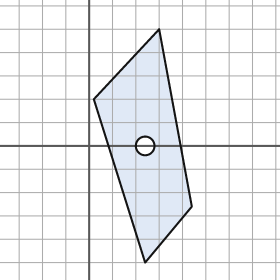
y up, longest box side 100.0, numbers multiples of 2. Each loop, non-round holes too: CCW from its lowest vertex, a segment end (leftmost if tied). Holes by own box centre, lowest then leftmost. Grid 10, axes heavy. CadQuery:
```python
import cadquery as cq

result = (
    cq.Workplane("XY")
    .moveTo(24.0, -50.0)
    .lineTo(44.0, -26.0)
    .lineTo(30.0, 50.0)
    .lineTo(2.0, 20.0)
    .close()
    .moveTo(24.0, 0.0)
    .circle(4.0)
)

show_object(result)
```